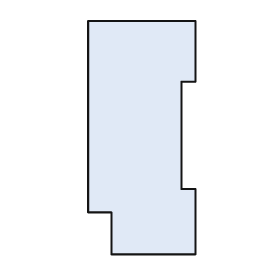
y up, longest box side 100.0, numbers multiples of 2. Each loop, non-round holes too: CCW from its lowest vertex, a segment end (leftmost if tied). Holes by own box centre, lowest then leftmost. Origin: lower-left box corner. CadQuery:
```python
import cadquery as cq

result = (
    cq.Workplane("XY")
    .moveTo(10.0, 0.0)
    .lineTo(46.0, 0.0)
    .lineTo(46.0, 28.0)
    .lineTo(40.0, 28.0)
    .lineTo(40.0, 74.0)
    .lineTo(46.0, 74.0)
    .lineTo(46.0, 100.0)
    .lineTo(0.0, 100.0)
    .lineTo(0.0, 18.0)
    .lineTo(10.0, 18.0)
    .close()
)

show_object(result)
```